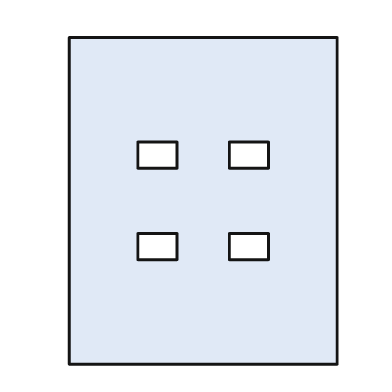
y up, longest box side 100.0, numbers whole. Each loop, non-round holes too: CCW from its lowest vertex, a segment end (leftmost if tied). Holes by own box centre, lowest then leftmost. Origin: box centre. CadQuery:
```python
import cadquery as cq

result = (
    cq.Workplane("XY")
    .moveTo(-41.0, -50.0)
    .lineTo(41.0, -50.0)
    .lineTo(41.0, 50.0)
    .lineTo(-41.0, 50.0)
    .close()
    .moveTo(-20.0, -18.0)
    .lineTo(-8.0, -18.0)
    .lineTo(-8.0, -10.0)
    .lineTo(-20.0, -10.0)
    .close()
    .moveTo(8.0, -18.0)
    .lineTo(20.0, -18.0)
    .lineTo(20.0, -10.0)
    .lineTo(8.0, -10.0)
    .close()
    .moveTo(-20.0, 10.0)
    .lineTo(-8.0, 10.0)
    .lineTo(-8.0, 18.0)
    .lineTo(-20.0, 18.0)
    .close()
    .moveTo(8.0, 10.0)
    .lineTo(20.0, 10.0)
    .lineTo(20.0, 18.0)
    .lineTo(8.0, 18.0)
    .close()
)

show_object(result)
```